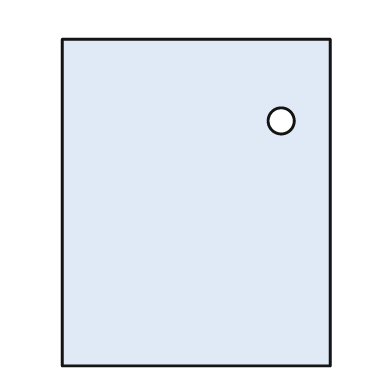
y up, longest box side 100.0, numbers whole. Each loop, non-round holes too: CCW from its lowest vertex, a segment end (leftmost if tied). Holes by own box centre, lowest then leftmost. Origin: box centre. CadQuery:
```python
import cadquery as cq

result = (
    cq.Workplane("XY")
    .moveTo(-41.0, -50.0)
    .lineTo(41.0, -50.0)
    .lineTo(41.0, 50.0)
    .lineTo(-41.0, 50.0)
    .close()
    .moveTo(26.0, 25.0)
    .circle(4.0)
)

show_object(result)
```